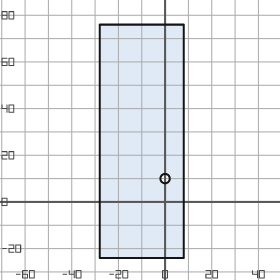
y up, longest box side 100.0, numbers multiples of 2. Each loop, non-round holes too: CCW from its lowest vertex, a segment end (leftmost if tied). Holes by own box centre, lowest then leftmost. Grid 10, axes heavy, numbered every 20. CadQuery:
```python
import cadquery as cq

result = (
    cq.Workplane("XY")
    .moveTo(-28.0, -24.0)
    .lineTo(8.0, -24.0)
    .lineTo(8.0, 76.0)
    .lineTo(-28.0, 76.0)
    .close()
    .moveTo(0.0, 10.0)
    .circle(2.0)
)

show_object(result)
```